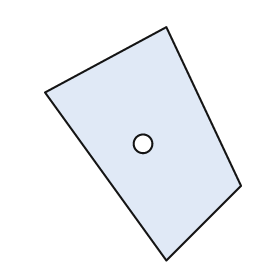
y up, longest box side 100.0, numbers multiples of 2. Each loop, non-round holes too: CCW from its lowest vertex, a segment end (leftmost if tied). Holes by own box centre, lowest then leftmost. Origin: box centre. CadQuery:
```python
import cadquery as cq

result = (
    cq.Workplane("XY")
    .moveTo(10.0, -50.0)
    .lineTo(42.0, -18.0)
    .lineTo(10.0, 50.0)
    .lineTo(-42.0, 22.0)
    .close()
    .moveTo(0.0, 0.0)
    .circle(4.0)
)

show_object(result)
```